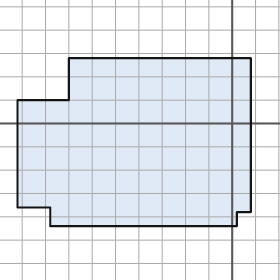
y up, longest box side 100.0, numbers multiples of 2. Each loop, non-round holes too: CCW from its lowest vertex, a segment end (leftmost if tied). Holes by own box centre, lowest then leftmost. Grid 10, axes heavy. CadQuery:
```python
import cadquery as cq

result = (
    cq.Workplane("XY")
    .moveTo(-78.0, -44.0)
    .lineTo(2.0, -44.0)
    .lineTo(2.0, -38.0)
    .lineTo(8.0, -38.0)
    .lineTo(8.0, 28.0)
    .lineTo(-70.0, 28.0)
    .lineTo(-70.0, 10.0)
    .lineTo(-92.0, 10.0)
    .lineTo(-92.0, -36.0)
    .lineTo(-78.0, -36.0)
    .close()
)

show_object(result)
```